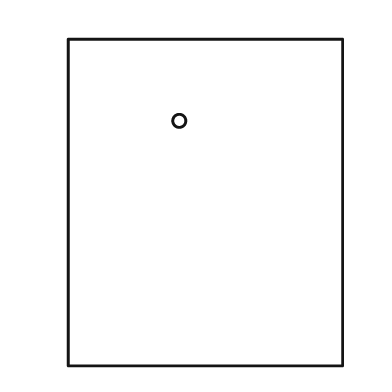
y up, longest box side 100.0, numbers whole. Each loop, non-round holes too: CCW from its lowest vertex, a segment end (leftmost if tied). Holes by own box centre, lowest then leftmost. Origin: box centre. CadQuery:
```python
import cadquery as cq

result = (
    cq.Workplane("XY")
    .moveTo(-42.0, -50.0)
    .lineTo(42.0, -50.0)
    .lineTo(42.0, 50.0)
    .lineTo(-42.0, 50.0)
    .close()
    .moveTo(-8.0, 25.0)
    .circle(2.0)
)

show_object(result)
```